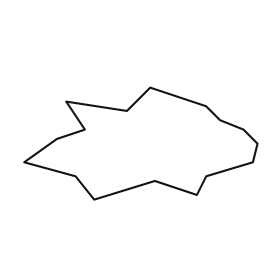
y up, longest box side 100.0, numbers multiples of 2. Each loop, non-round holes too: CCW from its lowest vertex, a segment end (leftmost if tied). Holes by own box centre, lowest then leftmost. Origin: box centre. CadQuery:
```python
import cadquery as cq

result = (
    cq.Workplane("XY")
    .moveTo(-20.0, -24.0)
    .lineTo(6.0, -16.0)
    .lineTo(24.0, -22.0)
    .lineTo(28.0, -14.0)
    .lineTo(48.0, -8.0)
    .lineTo(50.0, 0.0)
    .lineTo(44.0, 6.0)
    .lineTo(34.0, 10.0)
    .lineTo(28.0, 16.0)
    .lineTo(4.0, 24.0)
    .lineTo(-6.0, 14.0)
    .lineTo(-32.0, 18.0)
    .lineTo(-24.0, 6.0)
    .lineTo(-36.0, 2.0)
    .lineTo(-50.0, -8.0)
    .lineTo(-28.0, -14.0)
    .close()
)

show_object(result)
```